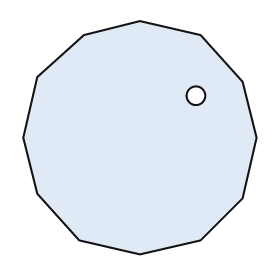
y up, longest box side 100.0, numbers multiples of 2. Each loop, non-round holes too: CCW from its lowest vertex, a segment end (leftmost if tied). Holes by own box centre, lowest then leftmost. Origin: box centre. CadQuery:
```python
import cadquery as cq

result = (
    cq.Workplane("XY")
    .moveTo(0.0, -50.0)
    .lineTo(26.0, -44.0)
    .lineTo(44.0, -26.0)
    .lineTo(50.0, 0.0)
    .lineTo(44.0, 24.0)
    .lineTo(26.0, 44.0)
    .lineTo(0.0, 50.0)
    .lineTo(-24.0, 44.0)
    .lineTo(-44.0, 26.0)
    .lineTo(-50.0, 0.0)
    .lineTo(-44.0, -24.0)
    .lineTo(-26.0, -44.0)
    .close()
    .moveTo(24.0, 18.0)
    .circle(4.0)
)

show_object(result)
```